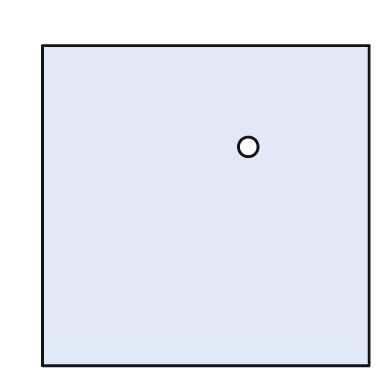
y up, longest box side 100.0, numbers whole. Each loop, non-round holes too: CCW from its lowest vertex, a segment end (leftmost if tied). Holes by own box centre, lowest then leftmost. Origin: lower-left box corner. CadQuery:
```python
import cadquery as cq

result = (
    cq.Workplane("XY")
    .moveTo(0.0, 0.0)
    .lineTo(100.0, 0.0)
    .lineTo(100.0, 98.0)
    .lineTo(0.0, 98.0)
    .close()
    .moveTo(63.0, 67.0)
    .circle(3.0)
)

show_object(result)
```